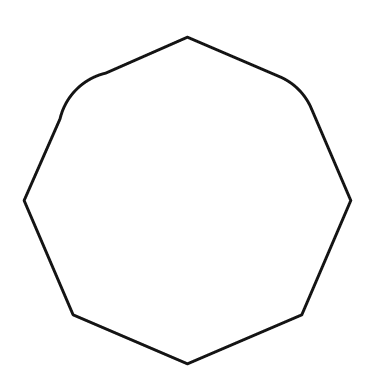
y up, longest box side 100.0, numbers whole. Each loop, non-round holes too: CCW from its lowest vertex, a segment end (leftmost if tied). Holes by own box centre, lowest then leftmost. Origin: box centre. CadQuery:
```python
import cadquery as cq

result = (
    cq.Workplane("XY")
    .moveTo(0.0, -50.0)
    .lineTo(35.0, -35.0)
    .lineTo(50.0, 0.0)
    .lineTo(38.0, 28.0)
    .threePointArc((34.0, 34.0), (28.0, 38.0))
    .lineTo(0.0, 50.0)
    .lineTo(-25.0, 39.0)
    .threePointArc((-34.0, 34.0), (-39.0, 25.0))
    .lineTo(-50.0, 0.0)
    .lineTo(-35.0, -35.0)
    .close()
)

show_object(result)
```